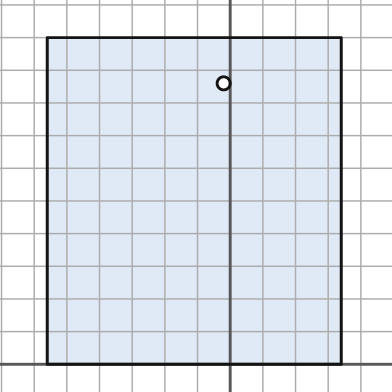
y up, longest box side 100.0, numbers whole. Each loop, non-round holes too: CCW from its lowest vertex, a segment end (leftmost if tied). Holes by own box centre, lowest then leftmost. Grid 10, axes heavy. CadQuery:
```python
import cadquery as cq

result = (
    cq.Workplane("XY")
    .moveTo(-56.0, 0.0)
    .lineTo(34.0, 0.0)
    .lineTo(34.0, 100.0)
    .lineTo(-56.0, 100.0)
    .close()
    .moveTo(-2.0, 86.0)
    .circle(2.0)
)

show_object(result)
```